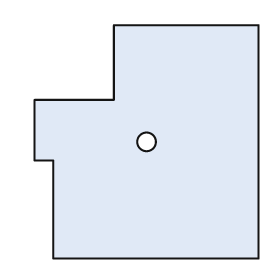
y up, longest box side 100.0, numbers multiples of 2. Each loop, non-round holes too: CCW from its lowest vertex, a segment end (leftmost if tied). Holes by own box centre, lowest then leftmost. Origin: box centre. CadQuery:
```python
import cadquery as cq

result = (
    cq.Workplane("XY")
    .moveTo(-40.0, -50.0)
    .lineTo(48.0, -50.0)
    .lineTo(48.0, 50.0)
    .lineTo(-14.0, 50.0)
    .lineTo(-14.0, 18.0)
    .lineTo(-48.0, 18.0)
    .lineTo(-48.0, -8.0)
    .lineTo(-40.0, -8.0)
    .close()
    .moveTo(0.0, 0.0)
    .circle(4.0)
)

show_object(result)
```